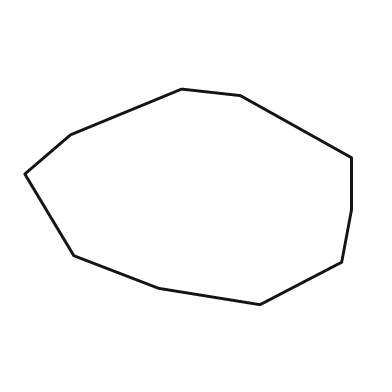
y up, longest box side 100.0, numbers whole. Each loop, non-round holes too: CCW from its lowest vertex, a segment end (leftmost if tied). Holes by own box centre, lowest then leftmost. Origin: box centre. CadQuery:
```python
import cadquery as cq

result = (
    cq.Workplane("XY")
    .moveTo(22.0, -33.0)
    .lineTo(47.0, -20.0)
    .lineTo(50.0, -4.0)
    .lineTo(50.0, 12.0)
    .lineTo(16.0, 31.0)
    .lineTo(-2.0, 33.0)
    .lineTo(-36.0, 19.0)
    .lineTo(-50.0, 7.0)
    .lineTo(-35.0, -18.0)
    .lineTo(-9.0, -28.0)
    .close()
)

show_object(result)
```